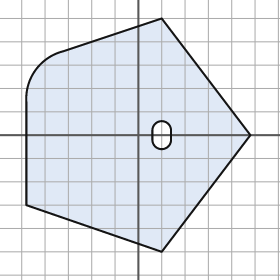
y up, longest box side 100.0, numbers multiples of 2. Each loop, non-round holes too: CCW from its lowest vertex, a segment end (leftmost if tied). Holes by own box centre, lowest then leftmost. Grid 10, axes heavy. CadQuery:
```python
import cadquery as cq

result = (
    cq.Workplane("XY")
    .moveTo(10.0, -50.0)
    .lineTo(48.0, 0.0)
    .lineTo(10.0, 50.0)
    .lineTo(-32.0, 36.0)
    .threePointArc((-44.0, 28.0), (-48.0, 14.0))
    .lineTo(-48.0, -30.0)
    .close()
    .moveTo(6.0, -2.0)
    .threePointArc((10.0, -6.0), (14.0, -2.0))
    .lineTo(14.0, 2.0)
    .threePointArc((10.0, 6.0), (6.0, 2.0))
    .close()
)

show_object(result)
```